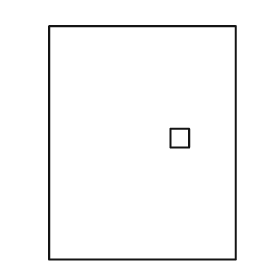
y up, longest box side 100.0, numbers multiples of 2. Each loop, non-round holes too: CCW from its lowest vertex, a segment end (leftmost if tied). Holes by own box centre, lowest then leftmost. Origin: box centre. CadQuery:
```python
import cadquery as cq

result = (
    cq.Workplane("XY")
    .moveTo(-40.0, -50.0)
    .lineTo(40.0, -50.0)
    .lineTo(40.0, 50.0)
    .lineTo(-40.0, 50.0)
    .close()
    .moveTo(12.0, -2.0)
    .lineTo(20.0, -2.0)
    .lineTo(20.0, 6.0)
    .lineTo(12.0, 6.0)
    .close()
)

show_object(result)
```